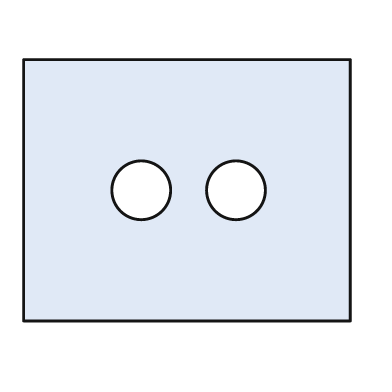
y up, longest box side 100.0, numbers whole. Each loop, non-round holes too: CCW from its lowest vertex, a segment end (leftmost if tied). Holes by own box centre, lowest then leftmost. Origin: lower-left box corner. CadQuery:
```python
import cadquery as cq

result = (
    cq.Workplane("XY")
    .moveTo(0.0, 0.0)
    .lineTo(100.0, 0.0)
    .lineTo(100.0, 80.0)
    .lineTo(0.0, 80.0)
    .close()
    .moveTo(36.0, 40.0)
    .circle(9.0)
    .moveTo(65.0, 40.0)
    .circle(9.0)
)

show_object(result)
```